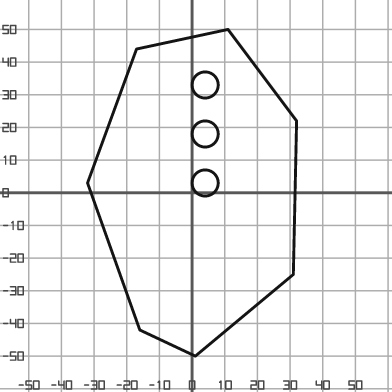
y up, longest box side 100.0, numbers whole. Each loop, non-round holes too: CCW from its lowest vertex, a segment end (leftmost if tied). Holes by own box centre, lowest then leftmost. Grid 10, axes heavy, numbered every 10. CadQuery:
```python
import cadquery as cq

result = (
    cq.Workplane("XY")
    .moveTo(1.0, -50.0)
    .lineTo(31.0, -25.0)
    .lineTo(32.0, 22.0)
    .lineTo(11.0, 50.0)
    .lineTo(-17.0, 44.0)
    .lineTo(-32.0, 3.0)
    .lineTo(-16.0, -42.0)
    .close()
    .moveTo(4.0, 3.0)
    .circle(4.0)
    .moveTo(4.0, 18.0)
    .circle(4.0)
    .moveTo(4.0, 33.0)
    .circle(4.0)
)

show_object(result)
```